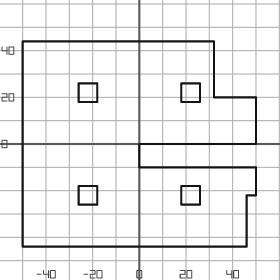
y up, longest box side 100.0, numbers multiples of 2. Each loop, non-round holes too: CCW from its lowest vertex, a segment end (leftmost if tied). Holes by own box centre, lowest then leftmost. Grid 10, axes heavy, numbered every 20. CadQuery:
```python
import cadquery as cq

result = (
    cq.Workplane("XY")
    .moveTo(-50.0, -44.0)
    .lineTo(46.0, -44.0)
    .lineTo(46.0, -22.0)
    .lineTo(50.0, -22.0)
    .lineTo(50.0, -10.0)
    .lineTo(0.0, -10.0)
    .lineTo(0.0, 0.0)
    .lineTo(50.0, 0.0)
    .lineTo(50.0, 20.0)
    .lineTo(32.0, 20.0)
    .lineTo(32.0, 44.0)
    .lineTo(-50.0, 44.0)
    .close()
    .moveTo(-26.0, -26.0)
    .lineTo(-18.0, -26.0)
    .lineTo(-18.0, -18.0)
    .lineTo(-26.0, -18.0)
    .close()
    .moveTo(18.0, -26.0)
    .lineTo(26.0, -26.0)
    .lineTo(26.0, -18.0)
    .lineTo(18.0, -18.0)
    .close()
    .moveTo(-26.0, 18.0)
    .lineTo(-18.0, 18.0)
    .lineTo(-18.0, 26.0)
    .lineTo(-26.0, 26.0)
    .close()
    .moveTo(18.0, 18.0)
    .lineTo(26.0, 18.0)
    .lineTo(26.0, 26.0)
    .lineTo(18.0, 26.0)
    .close()
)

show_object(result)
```